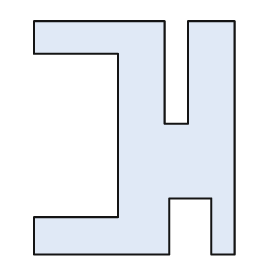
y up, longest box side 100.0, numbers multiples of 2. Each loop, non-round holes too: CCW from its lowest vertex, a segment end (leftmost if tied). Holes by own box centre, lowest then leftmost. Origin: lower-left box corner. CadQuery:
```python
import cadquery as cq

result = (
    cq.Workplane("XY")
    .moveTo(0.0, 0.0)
    .lineTo(58.0, 0.0)
    .lineTo(58.0, 24.0)
    .lineTo(76.0, 24.0)
    .lineTo(76.0, 0.0)
    .lineTo(86.0, 0.0)
    .lineTo(86.0, 100.0)
    .lineTo(66.0, 100.0)
    .lineTo(66.0, 56.0)
    .lineTo(56.0, 56.0)
    .lineTo(56.0, 100.0)
    .lineTo(0.0, 100.0)
    .lineTo(0.0, 86.0)
    .lineTo(36.0, 86.0)
    .lineTo(36.0, 16.0)
    .lineTo(0.0, 16.0)
    .close()
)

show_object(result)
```